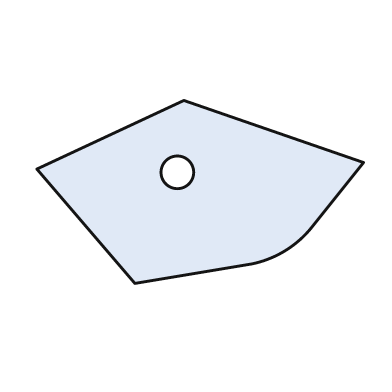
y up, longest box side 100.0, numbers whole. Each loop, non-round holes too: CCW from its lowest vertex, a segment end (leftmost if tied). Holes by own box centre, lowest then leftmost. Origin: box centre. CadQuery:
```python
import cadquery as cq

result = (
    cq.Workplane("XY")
    .moveTo(-20.0, -28.0)
    .lineTo(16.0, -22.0)
    .threePointArc((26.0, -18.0), (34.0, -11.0))
    .lineTo(50.0, 9.0)
    .lineTo(-5.0, 28.0)
    .lineTo(-50.0, 7.0)
    .close()
    .moveTo(-7.0, 6.0)
    .circle(5.0)
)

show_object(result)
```